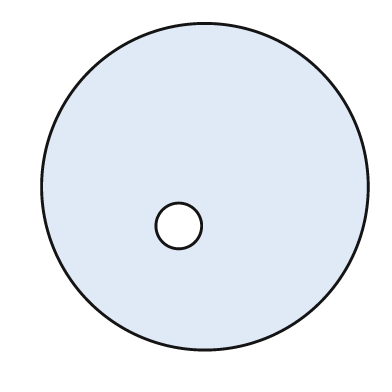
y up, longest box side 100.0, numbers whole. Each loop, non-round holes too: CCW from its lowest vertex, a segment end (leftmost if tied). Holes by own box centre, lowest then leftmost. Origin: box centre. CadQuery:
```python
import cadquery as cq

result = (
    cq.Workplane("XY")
    .moveTo(0.0, 0.0)
    .circle(50.0)
    .moveTo(-8.0, -12.0)
    .circle(7.0)
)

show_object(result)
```